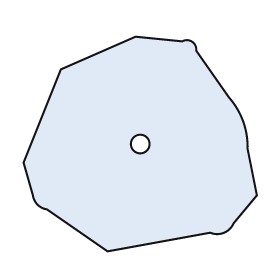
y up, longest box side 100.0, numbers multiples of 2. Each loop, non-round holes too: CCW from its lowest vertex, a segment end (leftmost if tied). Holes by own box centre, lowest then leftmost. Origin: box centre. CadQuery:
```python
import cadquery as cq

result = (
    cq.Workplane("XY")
    .moveTo(-14.0, -46.0)
    .lineTo(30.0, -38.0)
    .threePointArc((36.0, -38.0), (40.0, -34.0))
    .lineTo(50.0, -22.0)
    .lineTo(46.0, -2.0)
    .threePointArc((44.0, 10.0), (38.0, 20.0))
    .lineTo(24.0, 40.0)
    .threePointArc((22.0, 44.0), (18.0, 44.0))
    .lineTo(-2.0, 46.0)
    .lineTo(-34.0, 32.0)
    .lineTo(-50.0, -8.0)
    .lineTo(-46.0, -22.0)
    .threePointArc((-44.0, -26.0), (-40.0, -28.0))
    .close()
    .moveTo(0.0, 0.0)
    .circle(4.0)
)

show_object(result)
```